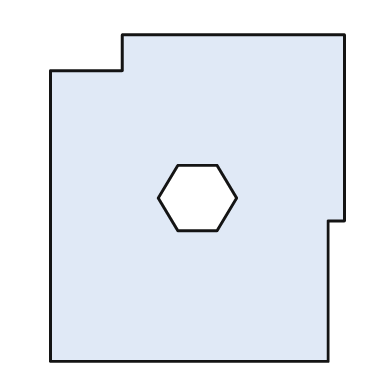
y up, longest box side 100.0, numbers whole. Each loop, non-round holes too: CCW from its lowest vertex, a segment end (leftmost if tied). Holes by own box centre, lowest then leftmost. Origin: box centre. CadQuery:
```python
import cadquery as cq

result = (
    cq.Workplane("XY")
    .moveTo(-45.0, -50.0)
    .lineTo(40.0, -50.0)
    .lineTo(40.0, -7.0)
    .lineTo(45.0, -7.0)
    .lineTo(45.0, 50.0)
    .lineTo(-23.0, 50.0)
    .lineTo(-23.0, 39.0)
    .lineTo(-45.0, 39.0)
    .close()
    .moveTo(-6.0, -10.0)
    .lineTo(6.0, -10.0)
    .lineTo(12.0, 0.0)
    .lineTo(6.0, 10.0)
    .lineTo(-6.0, 10.0)
    .lineTo(-12.0, 0.0)
    .close()
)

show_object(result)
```